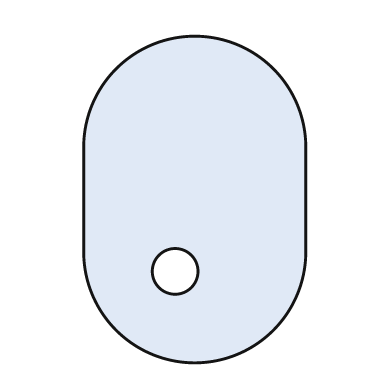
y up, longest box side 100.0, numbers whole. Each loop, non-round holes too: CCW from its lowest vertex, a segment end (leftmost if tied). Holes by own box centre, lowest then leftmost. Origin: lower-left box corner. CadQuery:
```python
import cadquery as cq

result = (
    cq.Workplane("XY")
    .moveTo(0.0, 34.0)
    .threePointArc((34.0, 0.0), (68.0, 34.0))
    .lineTo(68.0, 66.0)
    .threePointArc((34.0, 100.0), (0.0, 66.0))
    .close()
    .moveTo(28.0, 28.0)
    .circle(7.0)
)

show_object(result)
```